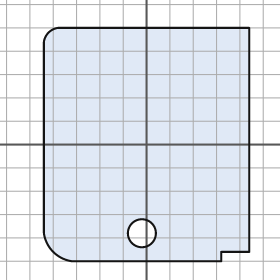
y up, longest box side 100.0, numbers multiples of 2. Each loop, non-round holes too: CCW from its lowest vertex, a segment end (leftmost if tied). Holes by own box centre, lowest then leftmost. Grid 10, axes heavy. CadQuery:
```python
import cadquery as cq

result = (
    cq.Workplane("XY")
    .moveTo(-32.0, -50.0)
    .lineTo(32.0, -50.0)
    .lineTo(32.0, -46.0)
    .lineTo(44.0, -46.0)
    .lineTo(44.0, 50.0)
    .lineTo(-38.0, 50.0)
    .threePointArc((-42.0, 48.0), (-44.0, 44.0))
    .lineTo(-44.0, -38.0)
    .threePointArc((-40.0, -46.0), (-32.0, -50.0))
    .close()
    .moveTo(-2.0, -38.0)
    .circle(6.0)
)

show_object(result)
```